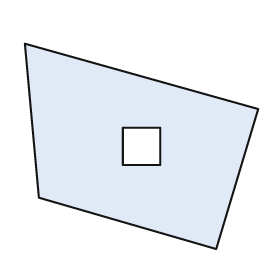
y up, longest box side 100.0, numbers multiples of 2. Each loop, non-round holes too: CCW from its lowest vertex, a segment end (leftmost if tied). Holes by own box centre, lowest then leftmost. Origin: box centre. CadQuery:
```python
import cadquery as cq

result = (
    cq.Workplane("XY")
    .moveTo(32.0, -44.0)
    .lineTo(50.0, 16.0)
    .lineTo(-50.0, 44.0)
    .lineTo(-44.0, -22.0)
    .close()
    .moveTo(-8.0, -8.0)
    .lineTo(8.0, -8.0)
    .lineTo(8.0, 8.0)
    .lineTo(-8.0, 8.0)
    .close()
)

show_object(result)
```